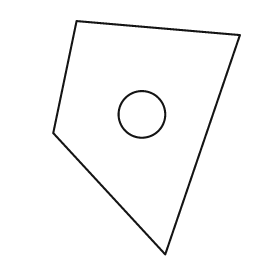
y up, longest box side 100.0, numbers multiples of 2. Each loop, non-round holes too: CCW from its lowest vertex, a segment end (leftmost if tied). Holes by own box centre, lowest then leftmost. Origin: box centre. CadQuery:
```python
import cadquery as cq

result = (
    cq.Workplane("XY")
    .moveTo(8.0, -50.0)
    .lineTo(40.0, 44.0)
    .lineTo(-30.0, 50.0)
    .lineTo(-40.0, 2.0)
    .close()
    .moveTo(-2.0, 10.0)
    .circle(10.0)
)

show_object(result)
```